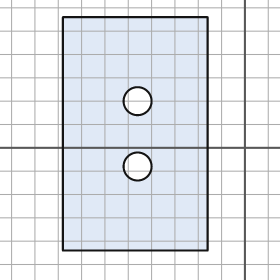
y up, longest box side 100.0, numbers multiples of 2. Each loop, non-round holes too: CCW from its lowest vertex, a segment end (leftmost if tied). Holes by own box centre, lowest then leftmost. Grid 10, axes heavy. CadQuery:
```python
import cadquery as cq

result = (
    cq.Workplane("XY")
    .moveTo(-78.0, -44.0)
    .lineTo(-16.0, -44.0)
    .lineTo(-16.0, 56.0)
    .lineTo(-78.0, 56.0)
    .close()
    .moveTo(-46.0, -8.0)
    .circle(6.0)
    .moveTo(-46.0, 20.0)
    .circle(6.0)
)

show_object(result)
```